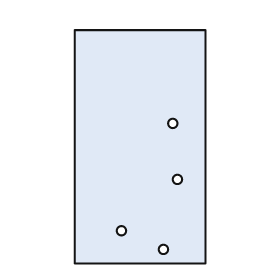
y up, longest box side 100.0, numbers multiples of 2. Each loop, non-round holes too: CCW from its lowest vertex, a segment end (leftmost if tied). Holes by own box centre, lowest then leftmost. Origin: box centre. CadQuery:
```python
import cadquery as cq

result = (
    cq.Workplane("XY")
    .moveTo(-28.0, -50.0)
    .lineTo(28.0, -50.0)
    .lineTo(28.0, 50.0)
    .lineTo(-28.0, 50.0)
    .close()
    .moveTo(10.0, -44.0)
    .circle(2.0)
    .moveTo(-8.0, -36.0)
    .circle(2.0)
    .moveTo(16.0, -14.0)
    .circle(2.0)
    .moveTo(14.0, 10.0)
    .circle(2.0)
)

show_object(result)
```